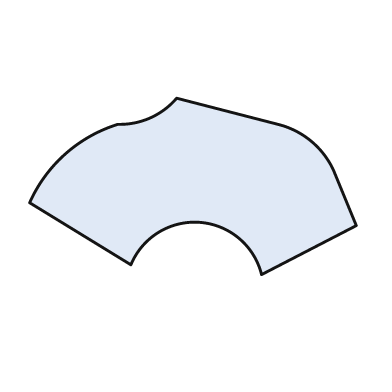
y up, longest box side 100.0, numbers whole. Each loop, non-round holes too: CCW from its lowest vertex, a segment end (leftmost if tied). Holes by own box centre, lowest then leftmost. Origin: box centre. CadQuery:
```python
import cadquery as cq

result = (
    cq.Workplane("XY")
    .moveTo(21.0, -27.0)
    .lineTo(50.0, -12.0)
    .lineTo(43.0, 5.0)
    .threePointArc((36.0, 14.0), (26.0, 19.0))
    .lineTo(-5.0, 27.0)
    .threePointArc((-13.0, 21.0), (-23.0, 19.0))
    .threePointArc((-39.0, 10.0), (-50.0, -5.0))
    .lineTo(-19.0, -24.0)
    .threePointArc((2.0, -11.0), (21.0, -27.0))
    .close()
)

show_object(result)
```